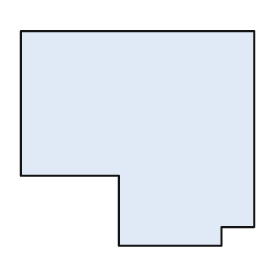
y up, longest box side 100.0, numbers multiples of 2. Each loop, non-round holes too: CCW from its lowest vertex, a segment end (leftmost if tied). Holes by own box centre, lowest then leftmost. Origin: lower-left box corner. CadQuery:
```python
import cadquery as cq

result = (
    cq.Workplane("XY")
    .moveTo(42.0, 0.0)
    .lineTo(86.0, 0.0)
    .lineTo(86.0, 8.0)
    .lineTo(100.0, 8.0)
    .lineTo(100.0, 92.0)
    .lineTo(0.0, 92.0)
    .lineTo(0.0, 30.0)
    .lineTo(42.0, 30.0)
    .close()
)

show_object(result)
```